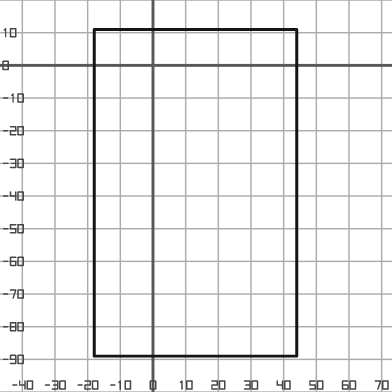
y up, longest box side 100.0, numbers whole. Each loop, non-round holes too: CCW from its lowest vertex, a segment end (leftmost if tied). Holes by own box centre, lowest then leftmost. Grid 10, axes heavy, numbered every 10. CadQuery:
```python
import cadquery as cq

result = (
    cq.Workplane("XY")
    .moveTo(-18.0, -89.0)
    .lineTo(44.0, -89.0)
    .lineTo(44.0, 11.0)
    .lineTo(-18.0, 11.0)
    .close()
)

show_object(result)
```